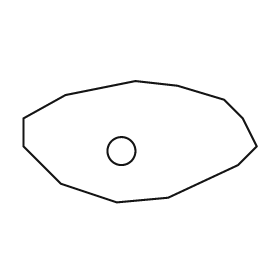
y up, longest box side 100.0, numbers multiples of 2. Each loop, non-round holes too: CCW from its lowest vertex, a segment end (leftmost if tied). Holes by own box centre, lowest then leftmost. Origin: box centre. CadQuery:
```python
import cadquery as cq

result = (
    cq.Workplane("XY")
    .moveTo(-10.0, -26.0)
    .lineTo(12.0, -24.0)
    .lineTo(42.0, -10.0)
    .lineTo(50.0, -2.0)
    .lineTo(44.0, 10.0)
    .lineTo(36.0, 18.0)
    .lineTo(16.0, 24.0)
    .lineTo(-2.0, 26.0)
    .lineTo(-32.0, 20.0)
    .lineTo(-50.0, 10.0)
    .lineTo(-50.0, -2.0)
    .lineTo(-34.0, -18.0)
    .close()
    .moveTo(-8.0, -4.0)
    .circle(6.0)
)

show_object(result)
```